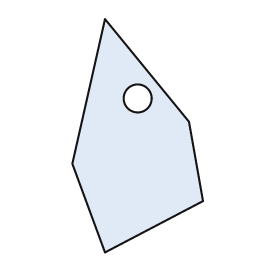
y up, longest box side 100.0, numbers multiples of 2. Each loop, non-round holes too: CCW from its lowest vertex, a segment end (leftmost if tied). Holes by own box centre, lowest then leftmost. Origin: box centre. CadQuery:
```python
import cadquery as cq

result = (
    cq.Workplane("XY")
    .moveTo(-14.0, -50.0)
    .lineTo(28.0, -28.0)
    .lineTo(22.0, 6.0)
    .lineTo(-14.0, 50.0)
    .lineTo(-28.0, -12.0)
    .close()
    .moveTo(0.0, 16.0)
    .circle(6.0)
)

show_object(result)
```